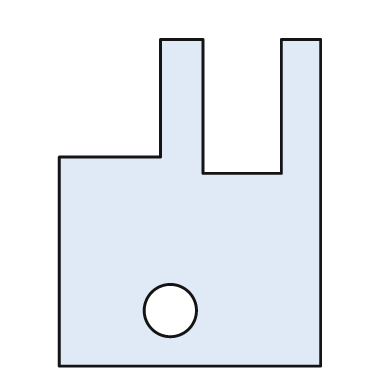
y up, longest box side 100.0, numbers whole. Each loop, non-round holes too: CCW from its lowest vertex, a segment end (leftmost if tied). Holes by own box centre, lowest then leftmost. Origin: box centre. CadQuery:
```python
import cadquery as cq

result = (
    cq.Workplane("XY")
    .moveTo(-40.0, -50.0)
    .lineTo(40.0, -50.0)
    .lineTo(40.0, 50.0)
    .lineTo(28.0, 50.0)
    .lineTo(28.0, 9.0)
    .lineTo(4.0, 9.0)
    .lineTo(4.0, 50.0)
    .lineTo(-9.0, 50.0)
    .lineTo(-9.0, 14.0)
    .lineTo(-40.0, 14.0)
    .close()
    .moveTo(-6.0, -33.0)
    .circle(8.0)
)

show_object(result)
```